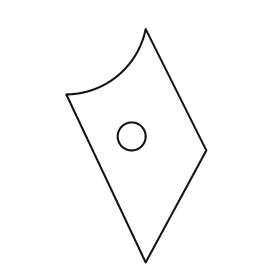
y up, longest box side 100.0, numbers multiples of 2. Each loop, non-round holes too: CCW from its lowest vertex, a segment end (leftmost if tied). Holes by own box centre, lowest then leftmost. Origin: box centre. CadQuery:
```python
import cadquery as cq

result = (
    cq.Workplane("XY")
    .moveTo(4.0, -50.0)
    .lineTo(30.0, -2.0)
    .lineTo(4.0, 50.0)
    .threePointArc((-8.0, 30.0), (-30.0, 22.0))
    .close()
    .moveTo(-2.0, 4.0)
    .circle(6.0)
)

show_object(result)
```